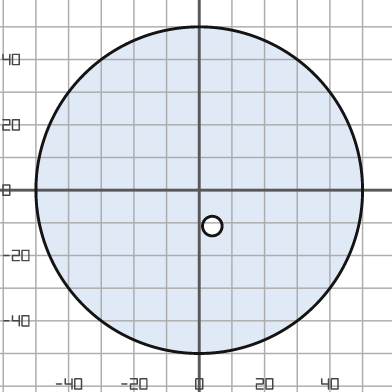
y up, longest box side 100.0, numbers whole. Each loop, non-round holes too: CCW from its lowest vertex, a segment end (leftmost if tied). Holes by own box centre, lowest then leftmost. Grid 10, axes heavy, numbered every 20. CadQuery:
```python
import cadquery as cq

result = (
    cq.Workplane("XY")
    .moveTo(0.0, 0.0)
    .circle(50.0)
    .moveTo(4.0, -11.0)
    .circle(3.0)
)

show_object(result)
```